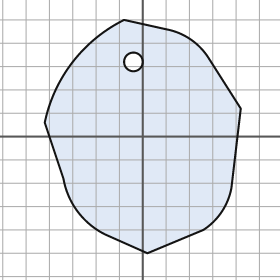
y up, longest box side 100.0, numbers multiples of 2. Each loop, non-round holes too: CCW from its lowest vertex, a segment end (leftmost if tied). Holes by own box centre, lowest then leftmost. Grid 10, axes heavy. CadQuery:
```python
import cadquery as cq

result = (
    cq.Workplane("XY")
    .moveTo(2.0, -50.0)
    .lineTo(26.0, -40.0)
    .threePointArc((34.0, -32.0), (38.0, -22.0))
    .lineTo(42.0, 12.0)
    .lineTo(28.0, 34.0)
    .threePointArc((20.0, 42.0), (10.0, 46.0))
    .lineTo(-8.0, 50.0)
    .threePointArc((-30.0, 32.0), (-42.0, 6.0))
    .lineTo(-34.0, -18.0)
    .threePointArc((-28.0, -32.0), (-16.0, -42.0))
    .close()
    .moveTo(-4.0, 32.0)
    .circle(4.0)
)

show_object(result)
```